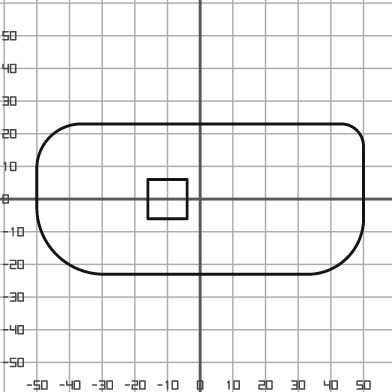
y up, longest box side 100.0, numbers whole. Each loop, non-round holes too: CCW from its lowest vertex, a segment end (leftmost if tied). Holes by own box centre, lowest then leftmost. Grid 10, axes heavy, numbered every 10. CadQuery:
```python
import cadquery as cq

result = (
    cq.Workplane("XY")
    .moveTo(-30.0, -23.0)
    .lineTo(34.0, -23.0)
    .threePointArc((45.0, -18.0), (50.0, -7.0))
    .lineTo(50.0, 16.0)
    .threePointArc((48.0, 21.0), (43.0, 23.0))
    .lineTo(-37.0, 23.0)
    .threePointArc((-46.0, 19.0), (-50.0, 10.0))
    .lineTo(-50.0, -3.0)
    .threePointArc((-44.0, -17.0), (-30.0, -23.0))
    .close()
    .moveTo(-16.0, -6.0)
    .lineTo(-4.0, -6.0)
    .lineTo(-4.0, 6.0)
    .lineTo(-16.0, 6.0)
    .close()
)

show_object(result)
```